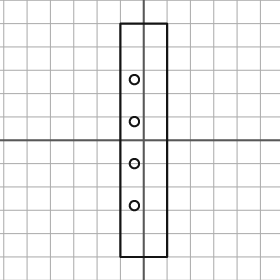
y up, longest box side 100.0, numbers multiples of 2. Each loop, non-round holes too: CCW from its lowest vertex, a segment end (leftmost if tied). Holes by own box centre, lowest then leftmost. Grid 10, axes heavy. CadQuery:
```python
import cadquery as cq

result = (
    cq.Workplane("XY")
    .moveTo(-10.0, -50.0)
    .lineTo(10.0, -50.0)
    .lineTo(10.0, 50.0)
    .lineTo(-10.0, 50.0)
    .close()
    .moveTo(-4.0, -28.0)
    .circle(2.0)
    .moveTo(-4.0, -10.0)
    .circle(2.0)
    .moveTo(-4.0, 8.0)
    .circle(2.0)
    .moveTo(-4.0, 26.0)
    .circle(2.0)
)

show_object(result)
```